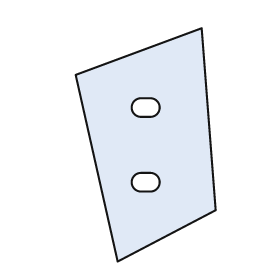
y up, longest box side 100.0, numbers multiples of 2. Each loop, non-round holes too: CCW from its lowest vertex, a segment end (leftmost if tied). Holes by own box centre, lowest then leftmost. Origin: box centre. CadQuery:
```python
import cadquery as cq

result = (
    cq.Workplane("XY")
    .moveTo(-12.0, -50.0)
    .lineTo(30.0, -28.0)
    .lineTo(24.0, 50.0)
    .lineTo(-30.0, 30.0)
    .close()
    .moveTo(-2.0, -20.0)
    .lineTo(2.0, -20.0)
    .threePointArc((6.0, -16.0), (2.0, -12.0))
    .lineTo(-2.0, -12.0)
    .threePointArc((-6.0, -16.0), (-2.0, -20.0))
    .close()
    .moveTo(-2.0, 12.0)
    .lineTo(2.0, 12.0)
    .threePointArc((6.0, 16.0), (2.0, 20.0))
    .lineTo(-2.0, 20.0)
    .threePointArc((-6.0, 16.0), (-2.0, 12.0))
    .close()
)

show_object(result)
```